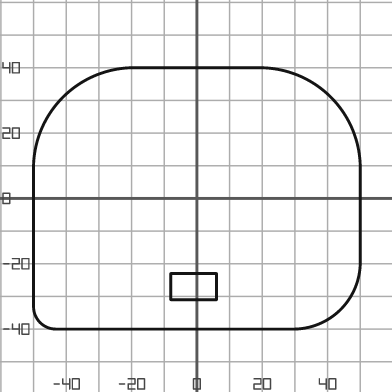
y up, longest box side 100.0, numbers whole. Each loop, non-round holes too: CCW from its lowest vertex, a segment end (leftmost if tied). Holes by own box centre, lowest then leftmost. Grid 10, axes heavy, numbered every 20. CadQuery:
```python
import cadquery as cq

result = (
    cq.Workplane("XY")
    .moveTo(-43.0, -40.0)
    .lineTo(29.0, -40.0)
    .threePointArc((44.0, -34.0), (50.0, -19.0))
    .lineTo(50.0, 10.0)
    .threePointArc((41.0, 31.0), (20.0, 40.0))
    .lineTo(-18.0, 40.0)
    .threePointArc((-41.0, 31.0), (-50.0, 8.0))
    .lineTo(-50.0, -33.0)
    .threePointArc((-48.0, -38.0), (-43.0, -40.0))
    .close()
    .moveTo(-8.0, -31.0)
    .lineTo(6.0, -31.0)
    .lineTo(6.0, -23.0)
    .lineTo(-8.0, -23.0)
    .close()
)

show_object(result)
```